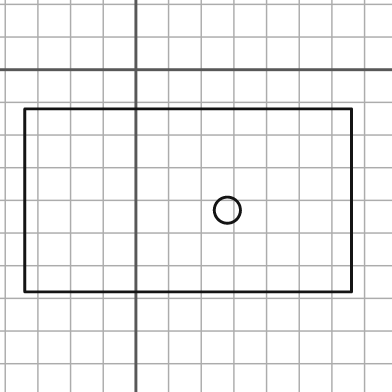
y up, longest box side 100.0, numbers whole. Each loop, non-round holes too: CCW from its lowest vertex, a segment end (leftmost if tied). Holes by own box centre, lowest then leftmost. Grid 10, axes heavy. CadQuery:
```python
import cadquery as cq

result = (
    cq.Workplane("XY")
    .moveTo(-34.0, -68.0)
    .lineTo(66.0, -68.0)
    .lineTo(66.0, -12.0)
    .lineTo(-34.0, -12.0)
    .close()
    .moveTo(28.0, -43.0)
    .circle(4.0)
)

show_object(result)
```